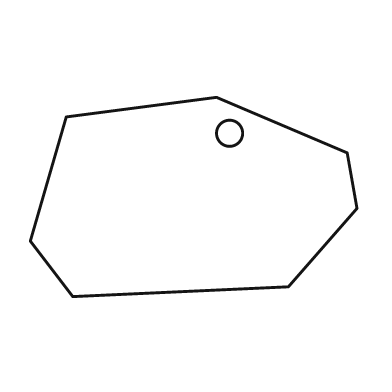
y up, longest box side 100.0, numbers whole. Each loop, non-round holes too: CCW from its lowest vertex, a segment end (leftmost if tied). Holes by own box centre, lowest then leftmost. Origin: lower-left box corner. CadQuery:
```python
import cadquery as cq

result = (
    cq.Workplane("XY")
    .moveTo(13.0, 0.0)
    .lineTo(79.0, 3.0)
    .lineTo(100.0, 27.0)
    .lineTo(97.0, 44.0)
    .lineTo(57.0, 61.0)
    .lineTo(11.0, 55.0)
    .lineTo(0.0, 17.0)
    .close()
    .moveTo(61.0, 50.0)
    .circle(4.0)
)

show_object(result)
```